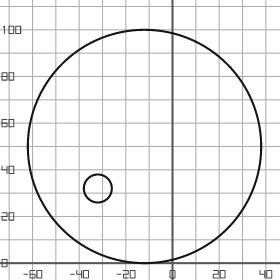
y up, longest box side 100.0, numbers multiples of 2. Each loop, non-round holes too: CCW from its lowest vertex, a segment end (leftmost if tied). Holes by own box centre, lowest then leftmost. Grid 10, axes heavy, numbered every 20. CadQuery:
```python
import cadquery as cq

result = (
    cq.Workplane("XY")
    .moveTo(-12.0, 50.0)
    .circle(50.0)
    .moveTo(-32.0, 32.0)
    .circle(6.0)
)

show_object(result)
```